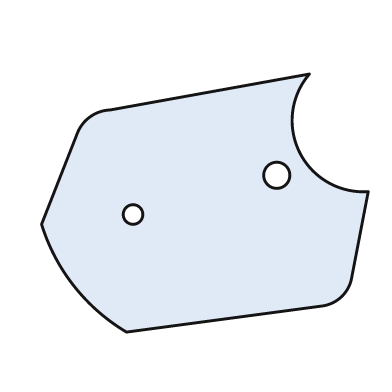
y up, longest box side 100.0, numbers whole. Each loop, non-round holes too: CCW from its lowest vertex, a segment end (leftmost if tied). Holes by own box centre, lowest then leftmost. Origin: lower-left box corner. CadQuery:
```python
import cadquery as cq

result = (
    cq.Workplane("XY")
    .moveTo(26.0, 0.0)
    .lineTo(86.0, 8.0)
    .threePointArc((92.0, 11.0), (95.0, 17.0))
    .lineTo(100.0, 43.0)
    .threePointArc((79.0, 55.0), (82.0, 79.0))
    .lineTo(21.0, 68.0)
    .threePointArc((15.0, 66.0), (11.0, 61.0))
    .lineTo(0.0, 33.0)
    .threePointArc((10.0, 14.0), (26.0, 0.0))
    .close()
    .moveTo(28.0, 36.0)
    .circle(3.0)
    .moveTo(72.0, 48.0)
    .circle(4.0)
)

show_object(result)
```